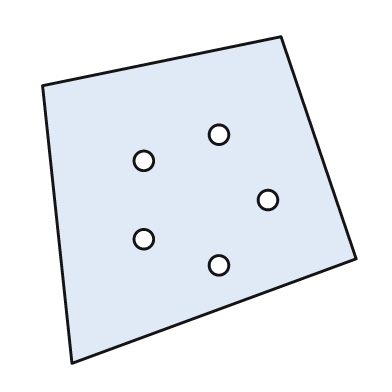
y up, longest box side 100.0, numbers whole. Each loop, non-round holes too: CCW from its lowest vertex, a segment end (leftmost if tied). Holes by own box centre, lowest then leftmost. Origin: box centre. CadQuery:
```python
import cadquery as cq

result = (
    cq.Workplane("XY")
    .moveTo(-39.0, -50.0)
    .lineTo(48.0, -18.0)
    .lineTo(25.0, 50.0)
    .lineTo(-48.0, 35.0)
    .close()
    .moveTo(6.0, -20.0)
    .circle(3.0)
    .moveTo(-17.0, -12.0)
    .circle(3.0)
    .moveTo(21.0, 0.0)
    .circle(3.0)
    .moveTo(-17.0, 12.0)
    .circle(3.0)
    .moveTo(6.0, 20.0)
    .circle(3.0)
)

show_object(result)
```